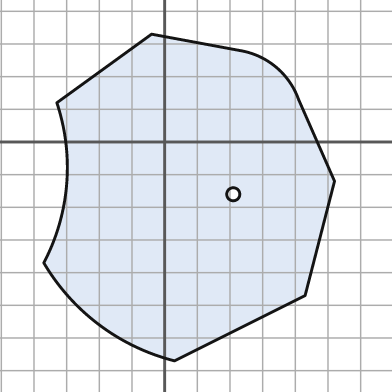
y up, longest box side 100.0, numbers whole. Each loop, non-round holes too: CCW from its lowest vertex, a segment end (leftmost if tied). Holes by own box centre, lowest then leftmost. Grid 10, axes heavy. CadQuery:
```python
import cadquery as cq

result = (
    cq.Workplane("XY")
    .moveTo(3.0, -67.0)
    .lineTo(43.0, -47.0)
    .lineTo(52.0, -12.0)
    .lineTo(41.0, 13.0)
    .threePointArc((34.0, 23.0), (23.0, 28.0))
    .lineTo(-4.0, 33.0)
    .lineTo(-33.0, 12.0)
    .threePointArc((-30.0, -13.0), (-37.0, -37.0))
    .threePointArc((-20.0, -56.0), (3.0, -67.0))
    .close()
    .moveTo(21.0, -16.0)
    .circle(2.0)
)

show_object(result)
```